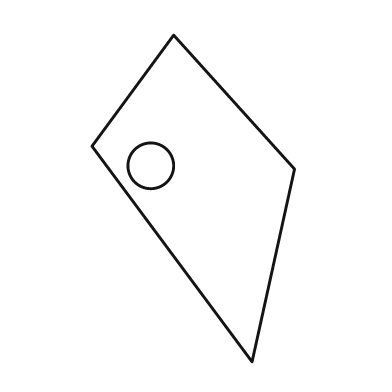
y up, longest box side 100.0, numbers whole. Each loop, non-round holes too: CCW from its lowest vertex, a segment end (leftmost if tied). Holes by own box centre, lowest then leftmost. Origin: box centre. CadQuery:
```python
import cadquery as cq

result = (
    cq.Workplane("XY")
    .moveTo(18.0, -50.0)
    .lineTo(31.0, 9.0)
    .lineTo(-6.0, 50.0)
    .lineTo(-31.0, 16.0)
    .close()
    .moveTo(-13.0, 10.0)
    .circle(7.0)
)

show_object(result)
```